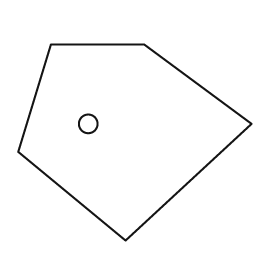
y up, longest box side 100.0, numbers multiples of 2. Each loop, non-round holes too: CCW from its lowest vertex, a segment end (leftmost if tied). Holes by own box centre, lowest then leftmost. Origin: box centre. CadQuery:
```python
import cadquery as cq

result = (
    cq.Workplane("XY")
    .moveTo(-4.0, -42.0)
    .lineTo(50.0, 8.0)
    .lineTo(4.0, 42.0)
    .lineTo(-36.0, 42.0)
    .lineTo(-50.0, -4.0)
    .close()
    .moveTo(-20.0, 8.0)
    .circle(4.0)
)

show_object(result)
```